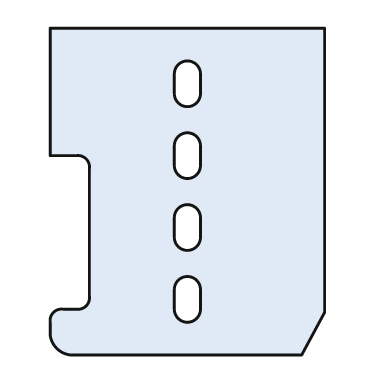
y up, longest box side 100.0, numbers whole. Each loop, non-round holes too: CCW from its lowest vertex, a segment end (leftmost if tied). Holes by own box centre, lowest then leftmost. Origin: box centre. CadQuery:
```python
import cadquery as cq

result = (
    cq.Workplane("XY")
    .moveTo(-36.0, -50.0)
    .lineTo(35.0, -50.0)
    .lineTo(42.0, -37.0)
    .lineTo(42.0, 50.0)
    .lineTo(-42.0, 50.0)
    .lineTo(-42.0, 11.0)
    .lineTo(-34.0, 11.0)
    .threePointArc((-31.0, 10.0), (-30.0, 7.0))
    .lineTo(-30.0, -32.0)
    .threePointArc((-31.0, -35.0), (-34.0, -36.0))
    .lineTo(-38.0, -36.0)
    .threePointArc((-41.0, -37.0), (-42.0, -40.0))
    .lineTo(-42.0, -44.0)
    .threePointArc((-40.0, -48.0), (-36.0, -50.0))
    .close()
    .moveTo(-4.0, -36.0)
    .threePointArc((0.0, -40.0), (4.0, -36.0))
    .lineTo(4.0, -30.0)
    .threePointArc((0.0, -26.0), (-4.0, -30.0))
    .close()
    .moveTo(-4.0, -14.0)
    .threePointArc((0.0, -18.0), (4.0, -14.0))
    .lineTo(4.0, -8.0)
    .threePointArc((0.0, -4.0), (-4.0, -8.0))
    .close()
    .moveTo(-4.0, 8.0)
    .threePointArc((0.0, 4.0), (4.0, 8.0))
    .lineTo(4.0, 14.0)
    .threePointArc((0.0, 18.0), (-4.0, 14.0))
    .close()
    .moveTo(-4.0, 30.0)
    .threePointArc((0.0, 26.0), (4.0, 30.0))
    .lineTo(4.0, 36.0)
    .threePointArc((0.0, 40.0), (-4.0, 36.0))
    .close()
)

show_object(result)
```